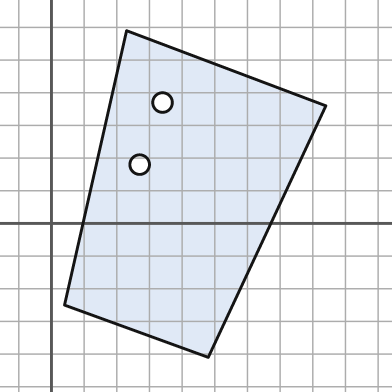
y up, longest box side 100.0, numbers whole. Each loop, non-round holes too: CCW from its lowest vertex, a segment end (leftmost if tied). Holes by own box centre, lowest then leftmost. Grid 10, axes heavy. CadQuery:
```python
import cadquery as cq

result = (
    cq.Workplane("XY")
    .moveTo(48.0, -41.0)
    .lineTo(84.0, 36.0)
    .lineTo(23.0, 59.0)
    .lineTo(4.0, -25.0)
    .close()
    .moveTo(27.0, 18.0)
    .circle(3.0)
    .moveTo(34.0, 37.0)
    .circle(3.0)
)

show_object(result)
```